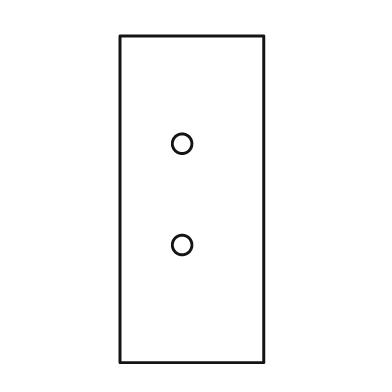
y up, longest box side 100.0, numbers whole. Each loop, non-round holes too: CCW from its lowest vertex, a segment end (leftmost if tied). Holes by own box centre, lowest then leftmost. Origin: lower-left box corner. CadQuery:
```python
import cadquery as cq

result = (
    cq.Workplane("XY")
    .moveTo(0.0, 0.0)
    .lineTo(44.0, 0.0)
    .lineTo(44.0, 100.0)
    .lineTo(0.0, 100.0)
    .close()
    .moveTo(19.0, 36.0)
    .circle(3.0)
    .moveTo(19.0, 67.0)
    .circle(3.0)
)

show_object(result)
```